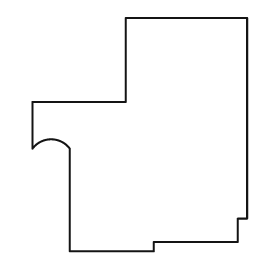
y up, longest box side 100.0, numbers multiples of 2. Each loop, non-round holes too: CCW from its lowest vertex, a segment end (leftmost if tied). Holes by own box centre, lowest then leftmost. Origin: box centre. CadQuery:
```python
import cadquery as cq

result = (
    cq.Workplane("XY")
    .moveTo(-30.0, -50.0)
    .lineTo(6.0, -50.0)
    .lineTo(6.0, -46.0)
    .lineTo(42.0, -46.0)
    .lineTo(42.0, -36.0)
    .lineTo(46.0, -36.0)
    .lineTo(46.0, 50.0)
    .lineTo(-6.0, 50.0)
    .lineTo(-6.0, 14.0)
    .lineTo(-46.0, 14.0)
    .lineTo(-46.0, -6.0)
    .threePointArc((-38.0, -2.0), (-30.0, -6.0))
    .close()
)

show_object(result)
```